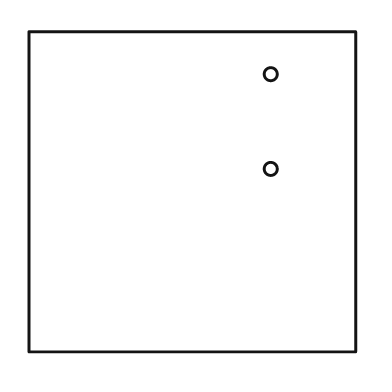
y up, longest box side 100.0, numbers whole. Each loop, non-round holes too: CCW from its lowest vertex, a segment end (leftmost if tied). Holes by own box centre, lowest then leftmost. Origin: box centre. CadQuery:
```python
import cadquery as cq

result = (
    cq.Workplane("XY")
    .moveTo(-50.0, -49.0)
    .lineTo(50.0, -49.0)
    .lineTo(50.0, 49.0)
    .lineTo(-50.0, 49.0)
    .close()
    .moveTo(24.0, 7.0)
    .circle(2.0)
    .moveTo(24.0, 36.0)
    .circle(2.0)
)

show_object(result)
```